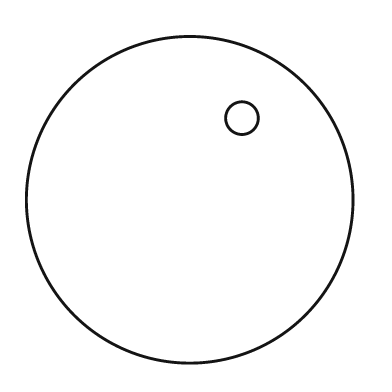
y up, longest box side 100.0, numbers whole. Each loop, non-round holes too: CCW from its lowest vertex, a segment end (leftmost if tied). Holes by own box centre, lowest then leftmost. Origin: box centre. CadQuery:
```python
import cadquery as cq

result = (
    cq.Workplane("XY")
    .moveTo(0.0, 0.0)
    .circle(50.0)
    .moveTo(16.0, 25.0)
    .circle(5.0)
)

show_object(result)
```